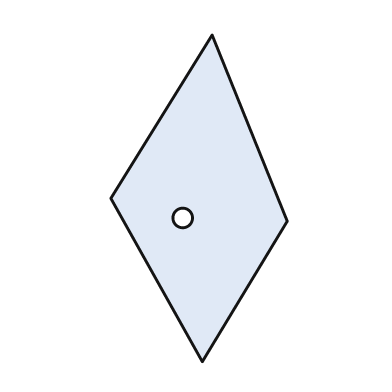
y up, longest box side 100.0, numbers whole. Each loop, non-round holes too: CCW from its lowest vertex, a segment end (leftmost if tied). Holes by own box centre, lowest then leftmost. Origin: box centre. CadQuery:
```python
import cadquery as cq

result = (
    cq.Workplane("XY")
    .moveTo(1.0, -50.0)
    .lineTo(27.0, -7.0)
    .lineTo(4.0, 50.0)
    .lineTo(-27.0, 0.0)
    .close()
    .moveTo(-5.0, -6.0)
    .circle(3.0)
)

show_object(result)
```